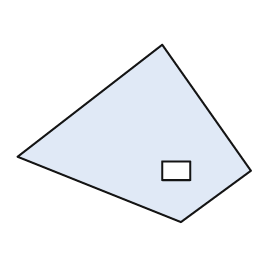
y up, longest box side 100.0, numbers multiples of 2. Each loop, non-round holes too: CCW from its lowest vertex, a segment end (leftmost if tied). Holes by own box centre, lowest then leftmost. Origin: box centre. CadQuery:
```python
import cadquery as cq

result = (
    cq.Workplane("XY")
    .moveTo(20.0, -38.0)
    .lineTo(50.0, -16.0)
    .lineTo(12.0, 38.0)
    .lineTo(-50.0, -10.0)
    .close()
    .moveTo(12.0, -20.0)
    .lineTo(24.0, -20.0)
    .lineTo(24.0, -12.0)
    .lineTo(12.0, -12.0)
    .close()
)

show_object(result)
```